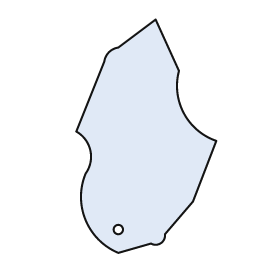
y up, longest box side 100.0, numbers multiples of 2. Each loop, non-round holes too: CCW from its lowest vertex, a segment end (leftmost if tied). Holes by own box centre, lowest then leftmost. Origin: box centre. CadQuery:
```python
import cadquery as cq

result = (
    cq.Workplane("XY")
    .moveTo(-12.0, -50.0)
    .lineTo(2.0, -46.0)
    .threePointArc((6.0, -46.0), (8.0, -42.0))
    .lineTo(20.0, -28.0)
    .lineTo(30.0, -2.0)
    .threePointArc((16.0, 10.0), (14.0, 28.0))
    .lineTo(4.0, 50.0)
    .lineTo(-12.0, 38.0)
    .threePointArc((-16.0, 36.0), (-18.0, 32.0))
    .lineTo(-30.0, 2.0)
    .threePointArc((-24.0, -6.0), (-26.0, -16.0))
    .threePointArc((-26.0, -36.0), (-12.0, -50.0))
    .close()
    .moveTo(-12.0, -40.0)
    .circle(2.0)
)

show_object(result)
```